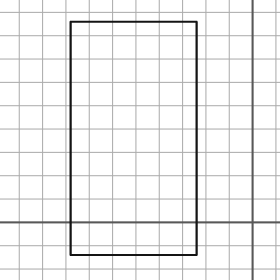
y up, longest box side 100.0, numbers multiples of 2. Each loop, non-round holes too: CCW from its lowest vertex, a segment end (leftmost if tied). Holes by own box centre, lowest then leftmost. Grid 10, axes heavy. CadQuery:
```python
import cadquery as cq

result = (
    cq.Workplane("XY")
    .moveTo(-78.0, -14.0)
    .lineTo(-24.0, -14.0)
    .lineTo(-24.0, 86.0)
    .lineTo(-78.0, 86.0)
    .close()
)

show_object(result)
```